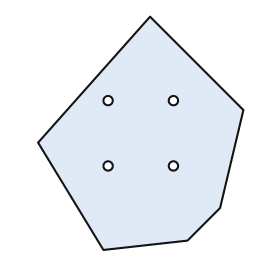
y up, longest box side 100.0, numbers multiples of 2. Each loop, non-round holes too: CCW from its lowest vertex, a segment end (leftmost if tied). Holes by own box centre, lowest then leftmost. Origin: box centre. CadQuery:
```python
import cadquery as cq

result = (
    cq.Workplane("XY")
    .moveTo(-16.0, -50.0)
    .lineTo(20.0, -46.0)
    .lineTo(34.0, -32.0)
    .lineTo(44.0, 10.0)
    .lineTo(4.0, 50.0)
    .lineTo(-44.0, -4.0)
    .close()
    .moveTo(-14.0, -14.0)
    .circle(2.0)
    .moveTo(14.0, -14.0)
    .circle(2.0)
    .moveTo(-14.0, 14.0)
    .circle(2.0)
    .moveTo(14.0, 14.0)
    .circle(2.0)
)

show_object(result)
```